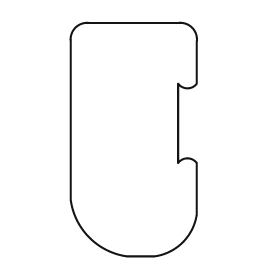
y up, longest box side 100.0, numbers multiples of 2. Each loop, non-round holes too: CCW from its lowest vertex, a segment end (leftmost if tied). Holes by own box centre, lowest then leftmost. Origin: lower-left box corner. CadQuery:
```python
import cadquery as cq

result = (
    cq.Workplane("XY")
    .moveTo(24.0, 0.0)
    .lineTo(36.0, 0.0)
    .threePointArc((48.0, 6.0), (54.0, 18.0))
    .lineTo(54.0, 40.0)
    .threePointArc((50.0, 42.0), (46.0, 40.0))
    .lineTo(46.0, 74.0)
    .threePointArc((50.0, 72.0), (54.0, 74.0))
    .lineTo(54.0, 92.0)
    .threePointArc((52.0, 98.0), (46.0, 100.0))
    .lineTo(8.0, 100.0)
    .threePointArc((2.0, 98.0), (0.0, 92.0))
    .lineTo(0.0, 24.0)
    .threePointArc((8.0, 8.0), (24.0, 0.0))
    .close()
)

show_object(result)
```